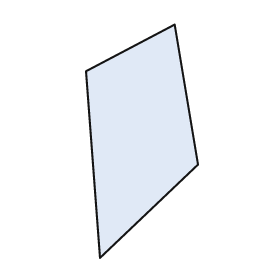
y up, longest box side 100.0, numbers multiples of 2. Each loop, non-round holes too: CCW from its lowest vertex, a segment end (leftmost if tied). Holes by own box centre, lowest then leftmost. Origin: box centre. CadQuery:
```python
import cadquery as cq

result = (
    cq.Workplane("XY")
    .moveTo(-18.0, -50.0)
    .lineTo(24.0, -10.0)
    .lineTo(14.0, 50.0)
    .lineTo(-24.0, 30.0)
    .close()
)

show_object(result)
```